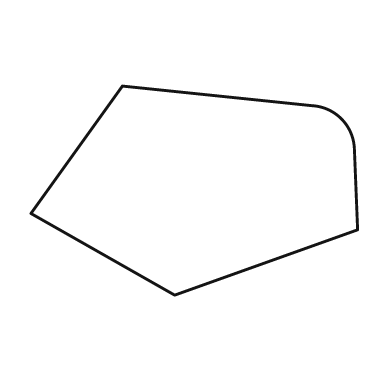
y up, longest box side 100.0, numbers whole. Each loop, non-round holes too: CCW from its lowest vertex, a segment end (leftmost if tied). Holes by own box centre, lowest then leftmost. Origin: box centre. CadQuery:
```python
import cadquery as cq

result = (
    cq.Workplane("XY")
    .moveTo(-6.0, -32.0)
    .lineTo(50.0, -12.0)
    .lineTo(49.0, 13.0)
    .threePointArc((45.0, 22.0), (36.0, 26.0))
    .lineTo(-22.0, 32.0)
    .lineTo(-50.0, -7.0)
    .close()
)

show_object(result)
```